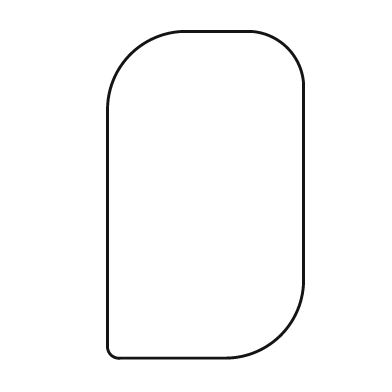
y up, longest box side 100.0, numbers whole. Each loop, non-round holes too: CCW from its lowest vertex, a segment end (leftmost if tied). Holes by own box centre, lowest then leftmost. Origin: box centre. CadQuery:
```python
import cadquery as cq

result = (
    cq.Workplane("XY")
    .moveTo(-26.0, -50.0)
    .lineTo(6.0, -50.0)
    .threePointArc((23.0, -43.0), (30.0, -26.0))
    .lineTo(30.0, 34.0)
    .threePointArc((25.0, 45.0), (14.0, 50.0))
    .lineTo(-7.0, 50.0)
    .threePointArc((-23.0, 43.0), (-30.0, 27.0))
    .lineTo(-30.0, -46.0)
    .threePointArc((-29.0, -49.0), (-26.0, -50.0))
    .close()
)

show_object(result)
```